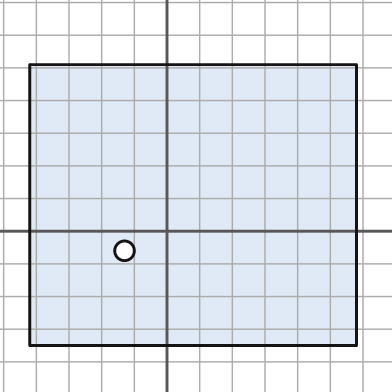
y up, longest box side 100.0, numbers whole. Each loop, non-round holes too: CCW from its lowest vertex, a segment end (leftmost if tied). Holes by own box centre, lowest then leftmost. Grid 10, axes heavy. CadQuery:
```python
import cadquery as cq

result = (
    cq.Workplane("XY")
    .moveTo(-42.0, -35.0)
    .lineTo(58.0, -35.0)
    .lineTo(58.0, 51.0)
    .lineTo(-42.0, 51.0)
    .close()
    .moveTo(-13.0, -6.0)
    .circle(3.0)
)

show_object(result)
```